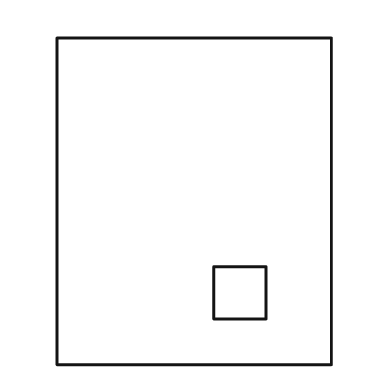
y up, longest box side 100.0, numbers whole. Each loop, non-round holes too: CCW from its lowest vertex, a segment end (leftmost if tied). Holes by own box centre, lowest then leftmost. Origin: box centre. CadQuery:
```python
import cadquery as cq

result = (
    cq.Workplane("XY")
    .moveTo(-42.0, -50.0)
    .lineTo(42.0, -50.0)
    .lineTo(42.0, 50.0)
    .lineTo(-42.0, 50.0)
    .close()
    .moveTo(6.0, -36.0)
    .lineTo(22.0, -36.0)
    .lineTo(22.0, -20.0)
    .lineTo(6.0, -20.0)
    .close()
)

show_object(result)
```